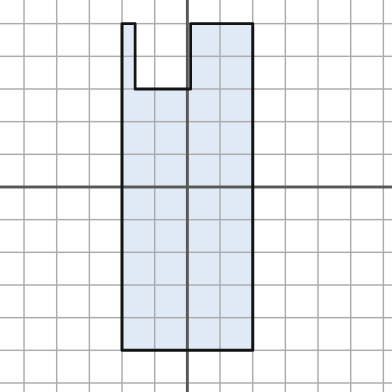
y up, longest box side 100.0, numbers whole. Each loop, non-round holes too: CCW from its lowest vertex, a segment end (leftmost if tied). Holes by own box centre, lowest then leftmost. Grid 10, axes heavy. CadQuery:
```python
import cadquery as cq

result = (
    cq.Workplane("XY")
    .moveTo(-20.0, -50.0)
    .lineTo(20.0, -50.0)
    .lineTo(20.0, 50.0)
    .lineTo(1.0, 50.0)
    .lineTo(1.0, 30.0)
    .lineTo(-16.0, 30.0)
    .lineTo(-16.0, 50.0)
    .lineTo(-20.0, 50.0)
    .close()
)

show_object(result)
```